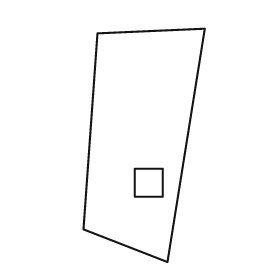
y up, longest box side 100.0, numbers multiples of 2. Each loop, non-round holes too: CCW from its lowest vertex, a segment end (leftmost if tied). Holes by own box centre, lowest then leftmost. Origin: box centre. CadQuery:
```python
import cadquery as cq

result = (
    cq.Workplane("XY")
    .moveTo(10.0, -50.0)
    .lineTo(26.0, 50.0)
    .lineTo(-20.0, 48.0)
    .lineTo(-26.0, -36.0)
    .close()
    .moveTo(-4.0, -22.0)
    .lineTo(8.0, -22.0)
    .lineTo(8.0, -10.0)
    .lineTo(-4.0, -10.0)
    .close()
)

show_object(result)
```